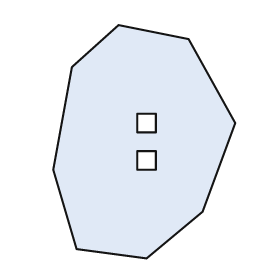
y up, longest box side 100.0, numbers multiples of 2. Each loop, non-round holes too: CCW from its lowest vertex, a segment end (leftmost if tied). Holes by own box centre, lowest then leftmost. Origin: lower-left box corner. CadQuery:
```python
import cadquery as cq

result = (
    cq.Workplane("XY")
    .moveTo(40.0, 0.0)
    .lineTo(64.0, 20.0)
    .lineTo(78.0, 58.0)
    .lineTo(58.0, 94.0)
    .lineTo(28.0, 100.0)
    .lineTo(8.0, 82.0)
    .lineTo(0.0, 38.0)
    .lineTo(10.0, 4.0)
    .close()
    .moveTo(36.0, 38.0)
    .lineTo(44.0, 38.0)
    .lineTo(44.0, 46.0)
    .lineTo(36.0, 46.0)
    .close()
    .moveTo(36.0, 54.0)
    .lineTo(44.0, 54.0)
    .lineTo(44.0, 62.0)
    .lineTo(36.0, 62.0)
    .close()
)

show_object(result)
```